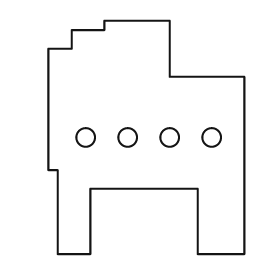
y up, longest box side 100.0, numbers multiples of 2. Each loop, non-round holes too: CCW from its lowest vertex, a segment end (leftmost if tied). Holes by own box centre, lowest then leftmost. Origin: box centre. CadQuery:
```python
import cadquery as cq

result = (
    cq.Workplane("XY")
    .moveTo(-38.0, -50.0)
    .lineTo(-24.0, -50.0)
    .lineTo(-24.0, -22.0)
    .lineTo(22.0, -22.0)
    .lineTo(22.0, -50.0)
    .lineTo(42.0, -50.0)
    .lineTo(42.0, 26.0)
    .lineTo(10.0, 26.0)
    .lineTo(10.0, 50.0)
    .lineTo(-18.0, 50.0)
    .lineTo(-18.0, 46.0)
    .lineTo(-32.0, 46.0)
    .lineTo(-32.0, 38.0)
    .lineTo(-42.0, 38.0)
    .lineTo(-42.0, -14.0)
    .lineTo(-38.0, -14.0)
    .close()
    .moveTo(-26.0, 0.0)
    .circle(4.0)
    .moveTo(-8.0, 0.0)
    .circle(4.0)
    .moveTo(10.0, 0.0)
    .circle(4.0)
    .moveTo(28.0, 0.0)
    .circle(4.0)
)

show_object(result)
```